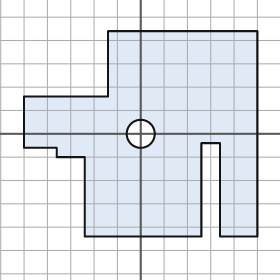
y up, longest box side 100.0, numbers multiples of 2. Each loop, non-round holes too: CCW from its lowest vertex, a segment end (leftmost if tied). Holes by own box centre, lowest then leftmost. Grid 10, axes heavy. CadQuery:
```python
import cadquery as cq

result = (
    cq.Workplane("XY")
    .moveTo(-24.0, -44.0)
    .lineTo(26.0, -44.0)
    .lineTo(26.0, -4.0)
    .lineTo(34.0, -4.0)
    .lineTo(34.0, -44.0)
    .lineTo(50.0, -44.0)
    .lineTo(50.0, 44.0)
    .lineTo(-14.0, 44.0)
    .lineTo(-14.0, 16.0)
    .lineTo(-50.0, 16.0)
    .lineTo(-50.0, -6.0)
    .lineTo(-36.0, -6.0)
    .lineTo(-36.0, -10.0)
    .lineTo(-24.0, -10.0)
    .close()
    .moveTo(0.0, 0.0)
    .circle(6.0)
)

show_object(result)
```